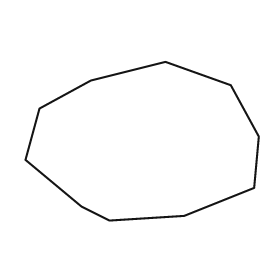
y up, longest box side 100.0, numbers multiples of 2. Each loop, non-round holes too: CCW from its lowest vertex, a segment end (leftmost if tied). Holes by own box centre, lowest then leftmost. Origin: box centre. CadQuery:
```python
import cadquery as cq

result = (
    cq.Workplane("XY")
    .moveTo(-14.0, -34.0)
    .lineTo(18.0, -32.0)
    .lineTo(48.0, -20.0)
    .lineTo(50.0, 2.0)
    .lineTo(38.0, 24.0)
    .lineTo(10.0, 34.0)
    .lineTo(-22.0, 26.0)
    .lineTo(-44.0, 14.0)
    .lineTo(-50.0, -8.0)
    .lineTo(-26.0, -28.0)
    .close()
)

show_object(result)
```